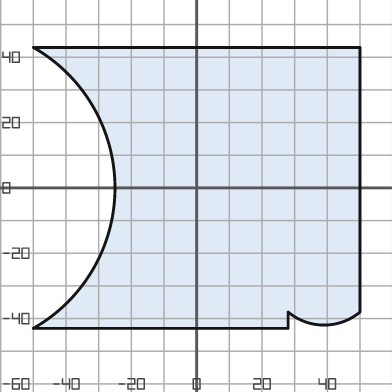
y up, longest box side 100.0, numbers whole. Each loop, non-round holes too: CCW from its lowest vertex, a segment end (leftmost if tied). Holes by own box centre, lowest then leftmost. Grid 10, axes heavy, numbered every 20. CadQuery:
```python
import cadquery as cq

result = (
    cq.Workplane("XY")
    .moveTo(-50.0, -43.0)
    .lineTo(28.0, -43.0)
    .lineTo(28.0, -38.0)
    .threePointArc((39.0, -42.0), (50.0, -38.0))
    .lineTo(50.0, 43.0)
    .lineTo(-50.0, 43.0)
    .threePointArc((-25.0, 0.0), (-50.0, -43.0))
    .close()
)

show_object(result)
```